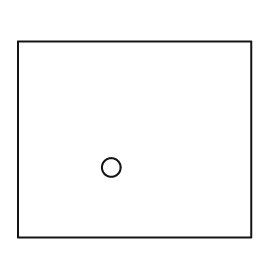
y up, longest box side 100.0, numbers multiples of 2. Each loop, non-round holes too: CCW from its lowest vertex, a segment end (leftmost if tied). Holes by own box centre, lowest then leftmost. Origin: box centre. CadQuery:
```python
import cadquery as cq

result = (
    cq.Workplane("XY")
    .moveTo(-50.0, -42.0)
    .lineTo(50.0, -42.0)
    .lineTo(50.0, 42.0)
    .lineTo(-50.0, 42.0)
    .close()
    .moveTo(-10.0, -12.0)
    .circle(4.0)
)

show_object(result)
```